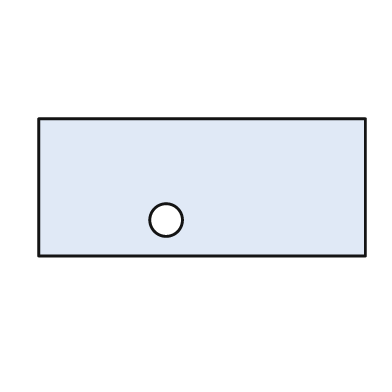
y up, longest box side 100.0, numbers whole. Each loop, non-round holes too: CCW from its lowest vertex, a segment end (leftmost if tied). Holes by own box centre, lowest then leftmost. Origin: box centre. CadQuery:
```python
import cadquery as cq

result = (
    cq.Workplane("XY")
    .moveTo(-50.0, -21.0)
    .lineTo(50.0, -21.0)
    .lineTo(50.0, 21.0)
    .lineTo(-50.0, 21.0)
    .close()
    .moveTo(-11.0, -10.0)
    .circle(5.0)
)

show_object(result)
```